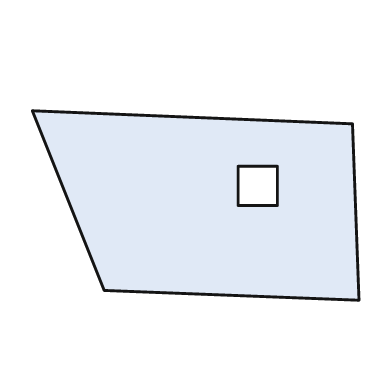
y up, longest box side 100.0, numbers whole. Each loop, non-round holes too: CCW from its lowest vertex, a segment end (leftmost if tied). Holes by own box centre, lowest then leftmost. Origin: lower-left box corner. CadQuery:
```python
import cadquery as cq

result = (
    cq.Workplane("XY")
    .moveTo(100.0, 0.0)
    .lineTo(98.0, 54.0)
    .lineTo(0.0, 58.0)
    .lineTo(22.0, 3.0)
    .close()
    .moveTo(63.0, 29.0)
    .lineTo(75.0, 29.0)
    .lineTo(75.0, 41.0)
    .lineTo(63.0, 41.0)
    .close()
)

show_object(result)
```